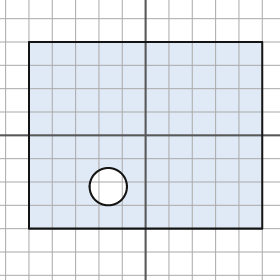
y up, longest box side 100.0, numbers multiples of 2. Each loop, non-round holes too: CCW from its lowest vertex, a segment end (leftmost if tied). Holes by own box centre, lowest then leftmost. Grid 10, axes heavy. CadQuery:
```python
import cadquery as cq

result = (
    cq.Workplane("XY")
    .moveTo(-50.0, -40.0)
    .lineTo(50.0, -40.0)
    .lineTo(50.0, 40.0)
    .lineTo(-50.0, 40.0)
    .close()
    .moveTo(-16.0, -22.0)
    .circle(8.0)
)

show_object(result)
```